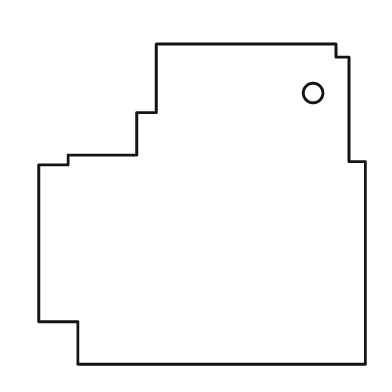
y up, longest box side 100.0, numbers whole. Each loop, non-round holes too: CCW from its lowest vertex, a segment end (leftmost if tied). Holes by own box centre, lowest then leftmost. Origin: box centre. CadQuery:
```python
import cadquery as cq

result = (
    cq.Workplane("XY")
    .moveTo(-38.0, -49.0)
    .lineTo(50.0, -49.0)
    .lineTo(50.0, 13.0)
    .lineTo(45.0, 13.0)
    .lineTo(45.0, 45.0)
    .lineTo(41.0, 45.0)
    .lineTo(41.0, 49.0)
    .lineTo(-14.0, 49.0)
    .lineTo(-14.0, 28.0)
    .lineTo(-20.0, 28.0)
    .lineTo(-20.0, 15.0)
    .lineTo(-41.0, 15.0)
    .lineTo(-41.0, 12.0)
    .lineTo(-50.0, 12.0)
    .lineTo(-50.0, -36.0)
    .lineTo(-38.0, -36.0)
    .close()
    .moveTo(34.0, 34.0)
    .circle(3.0)
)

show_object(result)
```